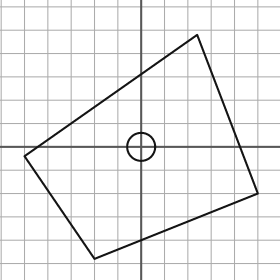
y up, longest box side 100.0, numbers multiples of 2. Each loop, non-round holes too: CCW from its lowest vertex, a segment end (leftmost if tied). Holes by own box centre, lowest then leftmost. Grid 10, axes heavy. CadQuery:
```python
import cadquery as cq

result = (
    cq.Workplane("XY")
    .moveTo(-20.0, -48.0)
    .lineTo(50.0, -20.0)
    .lineTo(24.0, 48.0)
    .lineTo(-50.0, -4.0)
    .close()
    .moveTo(0.0, 0.0)
    .circle(6.0)
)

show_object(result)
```